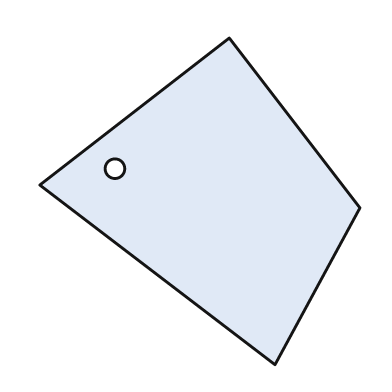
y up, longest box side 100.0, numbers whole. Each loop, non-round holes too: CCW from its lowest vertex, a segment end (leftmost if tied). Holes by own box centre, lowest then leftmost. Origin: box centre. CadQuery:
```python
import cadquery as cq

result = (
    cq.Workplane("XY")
    .moveTo(23.0, -50.0)
    .lineTo(49.0, -2.0)
    .lineTo(9.0, 50.0)
    .lineTo(-49.0, 5.0)
    .close()
    .moveTo(-26.0, 10.0)
    .circle(3.0)
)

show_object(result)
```